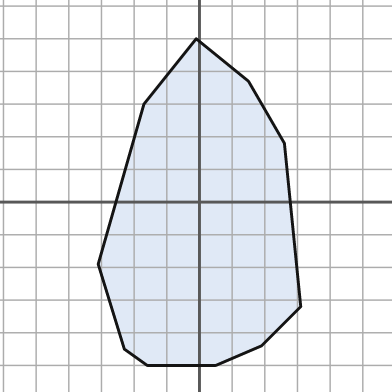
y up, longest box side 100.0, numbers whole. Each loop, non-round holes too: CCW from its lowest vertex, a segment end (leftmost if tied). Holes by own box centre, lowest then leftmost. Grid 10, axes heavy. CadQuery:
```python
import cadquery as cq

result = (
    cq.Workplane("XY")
    .moveTo(-16.0, -50.0)
    .lineTo(5.0, -50.0)
    .lineTo(19.0, -44.0)
    .lineTo(31.0, -32.0)
    .lineTo(26.0, 18.0)
    .lineTo(15.0, 37.0)
    .lineTo(-1.0, 50.0)
    .lineTo(-17.0, 30.0)
    .lineTo(-31.0, -19.0)
    .lineTo(-23.0, -45.0)
    .close()
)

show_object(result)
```